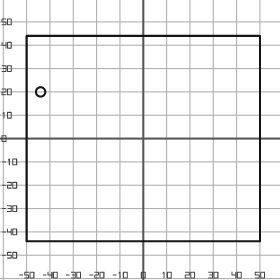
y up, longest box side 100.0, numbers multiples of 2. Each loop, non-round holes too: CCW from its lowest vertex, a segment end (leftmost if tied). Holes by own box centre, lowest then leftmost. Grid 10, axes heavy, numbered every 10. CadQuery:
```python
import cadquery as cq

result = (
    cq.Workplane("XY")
    .moveTo(-50.0, -44.0)
    .lineTo(50.0, -44.0)
    .lineTo(50.0, 44.0)
    .lineTo(-50.0, 44.0)
    .close()
    .moveTo(-44.0, 20.0)
    .circle(2.0)
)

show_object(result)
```